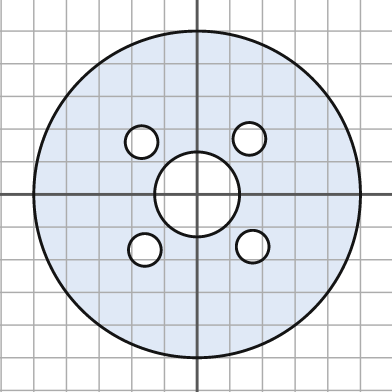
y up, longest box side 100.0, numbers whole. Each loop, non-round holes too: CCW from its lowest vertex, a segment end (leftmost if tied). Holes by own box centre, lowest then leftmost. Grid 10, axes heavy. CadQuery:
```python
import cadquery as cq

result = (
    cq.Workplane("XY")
    .moveTo(0.0, 0.0)
    .circle(50.0)
    .moveTo(-16.0, -17.0)
    .circle(5.0)
    .moveTo(17.0, -16.0)
    .circle(5.0)
    .moveTo(0.0, 0.0)
    .circle(13.0)
    .moveTo(-17.0, 16.0)
    .circle(5.0)
    .moveTo(16.0, 17.0)
    .circle(5.0)
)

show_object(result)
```